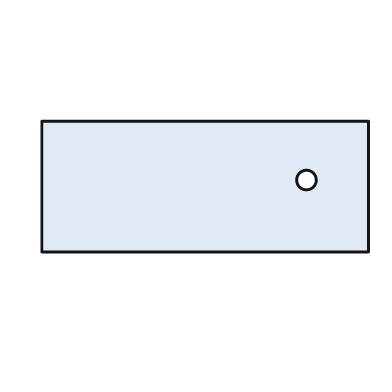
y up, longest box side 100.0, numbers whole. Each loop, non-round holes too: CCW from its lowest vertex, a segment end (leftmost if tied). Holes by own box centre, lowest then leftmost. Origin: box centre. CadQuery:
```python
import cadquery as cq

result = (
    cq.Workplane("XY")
    .moveTo(-50.0, -20.0)
    .lineTo(50.0, -20.0)
    .lineTo(50.0, 20.0)
    .lineTo(-50.0, 20.0)
    .close()
    .moveTo(31.0, 2.0)
    .circle(3.0)
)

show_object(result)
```